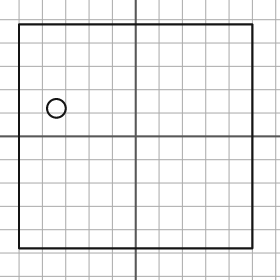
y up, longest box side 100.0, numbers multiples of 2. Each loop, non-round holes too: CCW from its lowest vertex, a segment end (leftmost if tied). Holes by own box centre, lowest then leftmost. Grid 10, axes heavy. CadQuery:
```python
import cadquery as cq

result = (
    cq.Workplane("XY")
    .moveTo(-50.0, -48.0)
    .lineTo(50.0, -48.0)
    .lineTo(50.0, 48.0)
    .lineTo(-50.0, 48.0)
    .close()
    .moveTo(-34.0, 12.0)
    .circle(4.0)
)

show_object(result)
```